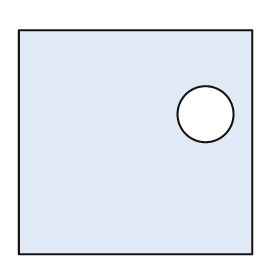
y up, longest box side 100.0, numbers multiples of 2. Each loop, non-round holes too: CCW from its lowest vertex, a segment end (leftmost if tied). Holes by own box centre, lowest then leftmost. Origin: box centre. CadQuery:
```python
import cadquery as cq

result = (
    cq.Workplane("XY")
    .moveTo(-50.0, -48.0)
    .lineTo(50.0, -48.0)
    .lineTo(50.0, 48.0)
    .lineTo(-50.0, 48.0)
    .close()
    .moveTo(30.0, 12.0)
    .circle(12.0)
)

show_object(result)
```